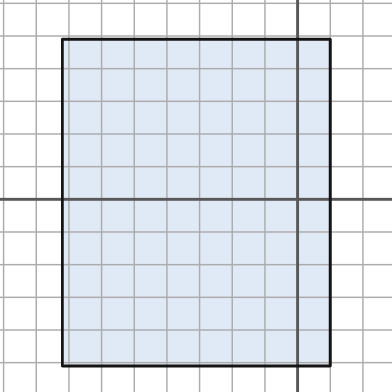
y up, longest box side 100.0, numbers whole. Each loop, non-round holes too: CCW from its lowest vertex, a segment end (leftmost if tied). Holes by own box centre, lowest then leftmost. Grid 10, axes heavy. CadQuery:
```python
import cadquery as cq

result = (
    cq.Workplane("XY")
    .moveTo(-72.0, -51.0)
    .lineTo(10.0, -51.0)
    .lineTo(10.0, 49.0)
    .lineTo(-72.0, 49.0)
    .close()
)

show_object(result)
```